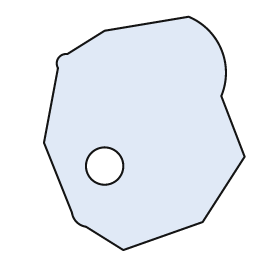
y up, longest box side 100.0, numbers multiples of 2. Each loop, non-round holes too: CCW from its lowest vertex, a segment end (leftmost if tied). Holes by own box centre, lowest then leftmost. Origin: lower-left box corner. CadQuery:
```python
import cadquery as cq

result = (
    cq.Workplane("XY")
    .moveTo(34.0, 0.0)
    .lineTo(68.0, 12.0)
    .lineTo(86.0, 40.0)
    .lineTo(76.0, 66.0)
    .threePointArc((76.0, 86.0), (62.0, 100.0))
    .lineTo(26.0, 94.0)
    .lineTo(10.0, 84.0)
    .threePointArc((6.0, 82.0), (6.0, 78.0))
    .lineTo(0.0, 46.0)
    .lineTo(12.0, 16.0)
    .threePointArc((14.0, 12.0), (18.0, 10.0))
    .close()
    .moveTo(26.0, 36.0)
    .circle(8.0)
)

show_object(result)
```